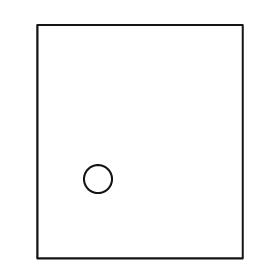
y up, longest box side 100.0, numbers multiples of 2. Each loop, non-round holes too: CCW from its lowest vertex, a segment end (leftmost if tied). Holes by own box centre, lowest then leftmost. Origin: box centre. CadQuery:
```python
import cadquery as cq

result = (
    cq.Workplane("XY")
    .moveTo(-44.0, -50.0)
    .lineTo(44.0, -50.0)
    .lineTo(44.0, 50.0)
    .lineTo(-44.0, 50.0)
    .close()
    .moveTo(-18.0, -16.0)
    .circle(6.0)
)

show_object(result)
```